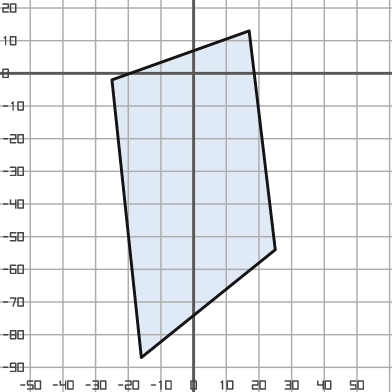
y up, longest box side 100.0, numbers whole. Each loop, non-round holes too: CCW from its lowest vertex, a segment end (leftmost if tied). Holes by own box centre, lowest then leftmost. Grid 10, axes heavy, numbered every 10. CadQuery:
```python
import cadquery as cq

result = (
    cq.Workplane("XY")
    .moveTo(-16.0, -87.0)
    .lineTo(25.0, -54.0)
    .lineTo(17.0, 13.0)
    .lineTo(-25.0, -2.0)
    .close()
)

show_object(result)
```